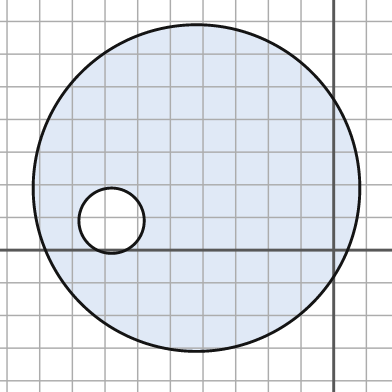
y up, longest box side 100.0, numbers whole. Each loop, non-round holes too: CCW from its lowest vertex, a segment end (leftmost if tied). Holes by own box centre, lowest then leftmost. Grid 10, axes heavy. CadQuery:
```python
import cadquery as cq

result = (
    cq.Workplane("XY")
    .moveTo(-42.0, 19.0)
    .circle(50.0)
    .moveTo(-68.0, 9.0)
    .circle(10.0)
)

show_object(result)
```